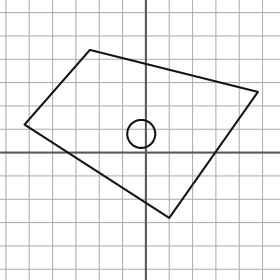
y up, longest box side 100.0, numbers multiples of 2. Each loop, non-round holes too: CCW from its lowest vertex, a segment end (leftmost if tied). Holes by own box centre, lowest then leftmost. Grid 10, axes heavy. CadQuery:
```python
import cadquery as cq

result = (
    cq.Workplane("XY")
    .moveTo(10.0, -28.0)
    .lineTo(48.0, 26.0)
    .lineTo(-24.0, 44.0)
    .lineTo(-52.0, 12.0)
    .close()
    .moveTo(-2.0, 8.0)
    .circle(6.0)
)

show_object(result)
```